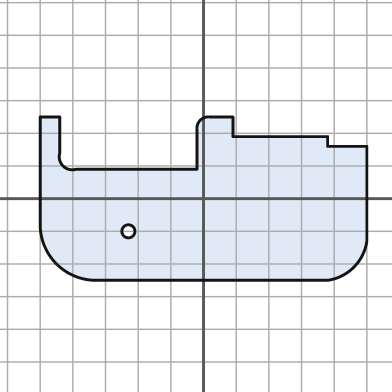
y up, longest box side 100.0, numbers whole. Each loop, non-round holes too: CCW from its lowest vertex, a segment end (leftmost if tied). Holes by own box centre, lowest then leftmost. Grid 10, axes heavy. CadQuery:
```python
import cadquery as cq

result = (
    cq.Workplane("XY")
    .moveTo(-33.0, -25.0)
    .lineTo(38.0, -25.0)
    .threePointArc((46.0, -21.0), (50.0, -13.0))
    .lineTo(50.0, 16.0)
    .lineTo(38.0, 16.0)
    .lineTo(38.0, 19.0)
    .lineTo(9.0, 19.0)
    .lineTo(9.0, 25.0)
    .lineTo(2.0, 25.0)
    .threePointArc((-1.0, 24.0), (-2.0, 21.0))
    .lineTo(-2.0, 9.0)
    .lineTo(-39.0, 9.0)
    .threePointArc((-43.0, 10.0), (-44.0, 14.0))
    .lineTo(-44.0, 25.0)
    .lineTo(-50.0, 25.0)
    .lineTo(-50.0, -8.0)
    .threePointArc((-45.0, -20.0), (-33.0, -25.0))
    .close()
    .moveTo(-23.0, -10.0)
    .circle(2.0)
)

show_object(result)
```